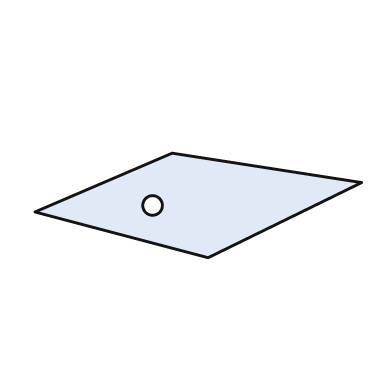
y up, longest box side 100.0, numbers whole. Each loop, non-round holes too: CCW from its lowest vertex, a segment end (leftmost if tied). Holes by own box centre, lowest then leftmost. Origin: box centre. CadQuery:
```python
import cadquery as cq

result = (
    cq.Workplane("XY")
    .moveTo(3.0, -16.0)
    .lineTo(50.0, 7.0)
    .lineTo(-8.0, 16.0)
    .lineTo(-50.0, -2.0)
    .close()
    .moveTo(-14.0, 0.0)
    .circle(3.0)
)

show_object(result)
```